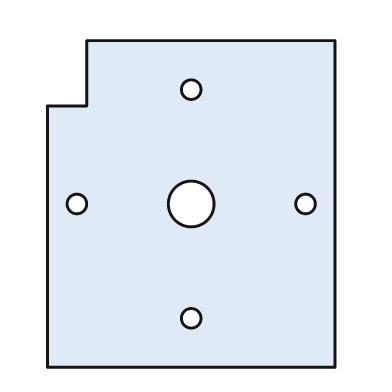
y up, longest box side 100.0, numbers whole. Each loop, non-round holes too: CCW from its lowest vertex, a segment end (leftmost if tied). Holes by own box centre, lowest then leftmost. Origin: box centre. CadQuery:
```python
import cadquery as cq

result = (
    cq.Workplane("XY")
    .moveTo(-44.0, -50.0)
    .lineTo(44.0, -50.0)
    .lineTo(44.0, 50.0)
    .lineTo(-32.0, 50.0)
    .lineTo(-32.0, 30.0)
    .lineTo(-44.0, 30.0)
    .close()
    .moveTo(0.0, -35.0)
    .circle(3.0)
    .moveTo(-35.0, 0.0)
    .circle(3.0)
    .moveTo(0.0, 0.0)
    .circle(7.0)
    .moveTo(35.0, 0.0)
    .circle(3.0)
    .moveTo(0.0, 35.0)
    .circle(3.0)
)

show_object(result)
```